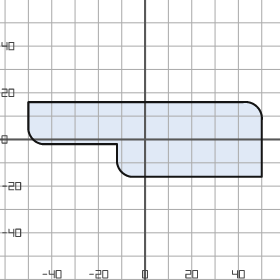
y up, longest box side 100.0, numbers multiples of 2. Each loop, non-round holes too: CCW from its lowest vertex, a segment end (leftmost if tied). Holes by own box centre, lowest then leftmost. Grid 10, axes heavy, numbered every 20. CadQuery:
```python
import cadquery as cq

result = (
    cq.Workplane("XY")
    .moveTo(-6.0, -16.0)
    .lineTo(50.0, -16.0)
    .lineTo(50.0, 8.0)
    .threePointArc((48.0, 14.0), (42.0, 16.0))
    .lineTo(-50.0, 16.0)
    .lineTo(-50.0, 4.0)
    .threePointArc((-48.0, 0.0), (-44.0, -2.0))
    .lineTo(-12.0, -2.0)
    .lineTo(-12.0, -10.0)
    .threePointArc((-10.0, -14.0), (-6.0, -16.0))
    .close()
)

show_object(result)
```